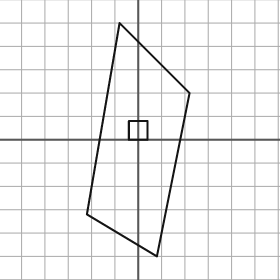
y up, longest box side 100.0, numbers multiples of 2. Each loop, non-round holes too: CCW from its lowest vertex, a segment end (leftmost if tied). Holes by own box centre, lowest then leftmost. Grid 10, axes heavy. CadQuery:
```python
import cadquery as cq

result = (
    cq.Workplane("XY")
    .moveTo(8.0, -50.0)
    .lineTo(22.0, 20.0)
    .lineTo(-8.0, 50.0)
    .lineTo(-22.0, -32.0)
    .close()
    .moveTo(-4.0, 0.0)
    .lineTo(4.0, 0.0)
    .lineTo(4.0, 8.0)
    .lineTo(-4.0, 8.0)
    .close()
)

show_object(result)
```